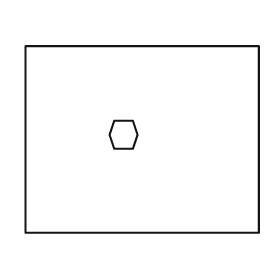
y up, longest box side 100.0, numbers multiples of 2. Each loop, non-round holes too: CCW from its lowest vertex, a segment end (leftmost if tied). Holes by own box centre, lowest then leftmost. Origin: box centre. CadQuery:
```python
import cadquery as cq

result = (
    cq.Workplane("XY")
    .moveTo(-50.0, -40.0)
    .lineTo(50.0, -40.0)
    .lineTo(50.0, 40.0)
    .lineTo(-50.0, 40.0)
    .close()
    .moveTo(-12.0, -4.0)
    .lineTo(-4.0, -4.0)
    .lineTo(-2.0, 2.0)
    .lineTo(-4.0, 8.0)
    .lineTo(-12.0, 8.0)
    .lineTo(-14.0, 2.0)
    .close()
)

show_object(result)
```